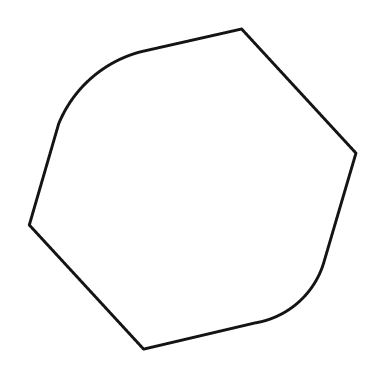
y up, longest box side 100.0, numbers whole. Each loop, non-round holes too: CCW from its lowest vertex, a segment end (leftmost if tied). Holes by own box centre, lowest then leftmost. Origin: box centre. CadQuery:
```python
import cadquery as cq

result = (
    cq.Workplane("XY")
    .moveTo(-15.0, -49.0)
    .lineTo(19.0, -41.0)
    .threePointArc((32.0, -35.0), (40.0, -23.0))
    .lineTo(50.0, 11.0)
    .lineTo(15.0, 49.0)
    .lineTo(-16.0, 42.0)
    .threePointArc((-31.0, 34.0), (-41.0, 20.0))
    .lineTo(-50.0, -11.0)
    .close()
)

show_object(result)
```